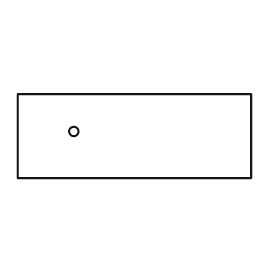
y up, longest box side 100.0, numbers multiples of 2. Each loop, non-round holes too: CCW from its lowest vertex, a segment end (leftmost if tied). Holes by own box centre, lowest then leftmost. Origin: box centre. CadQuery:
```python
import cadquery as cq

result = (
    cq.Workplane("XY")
    .moveTo(-50.0, -18.0)
    .lineTo(50.0, -18.0)
    .lineTo(50.0, 18.0)
    .lineTo(-50.0, 18.0)
    .close()
    .moveTo(-26.0, 2.0)
    .circle(2.0)
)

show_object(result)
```